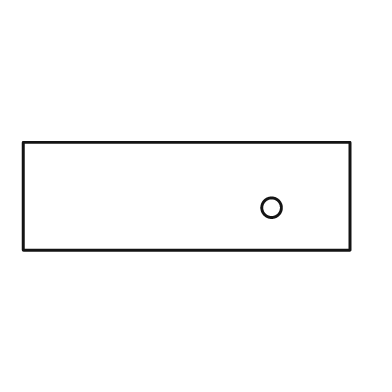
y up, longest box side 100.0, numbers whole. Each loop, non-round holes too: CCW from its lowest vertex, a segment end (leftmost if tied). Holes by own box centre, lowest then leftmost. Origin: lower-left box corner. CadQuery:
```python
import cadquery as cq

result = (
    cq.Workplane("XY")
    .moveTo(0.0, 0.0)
    .lineTo(100.0, 0.0)
    .lineTo(100.0, 33.0)
    .lineTo(0.0, 33.0)
    .close()
    .moveTo(76.0, 13.0)
    .circle(3.0)
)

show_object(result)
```